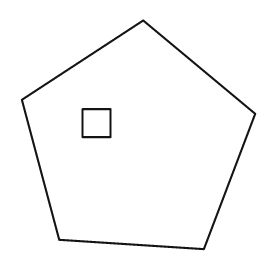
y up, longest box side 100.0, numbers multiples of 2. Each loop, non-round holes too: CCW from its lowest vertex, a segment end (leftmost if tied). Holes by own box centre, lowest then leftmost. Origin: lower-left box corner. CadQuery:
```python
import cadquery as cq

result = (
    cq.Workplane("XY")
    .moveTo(78.0, 0.0)
    .lineTo(100.0, 58.0)
    .lineTo(52.0, 98.0)
    .lineTo(0.0, 64.0)
    .lineTo(16.0, 4.0)
    .close()
    .moveTo(26.0, 48.0)
    .lineTo(38.0, 48.0)
    .lineTo(38.0, 60.0)
    .lineTo(26.0, 60.0)
    .close()
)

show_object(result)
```